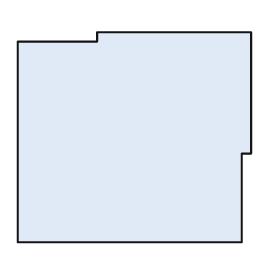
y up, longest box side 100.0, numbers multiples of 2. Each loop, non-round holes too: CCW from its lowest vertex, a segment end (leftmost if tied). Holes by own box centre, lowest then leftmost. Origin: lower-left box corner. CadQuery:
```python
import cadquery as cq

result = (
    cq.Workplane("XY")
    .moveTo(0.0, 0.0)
    .lineTo(96.0, 0.0)
    .lineTo(96.0, 38.0)
    .lineTo(100.0, 38.0)
    .lineTo(100.0, 90.0)
    .lineTo(34.0, 90.0)
    .lineTo(34.0, 86.0)
    .lineTo(0.0, 86.0)
    .close()
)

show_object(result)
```